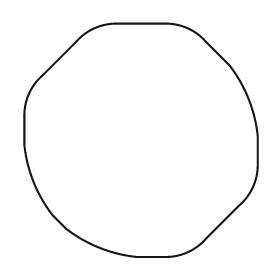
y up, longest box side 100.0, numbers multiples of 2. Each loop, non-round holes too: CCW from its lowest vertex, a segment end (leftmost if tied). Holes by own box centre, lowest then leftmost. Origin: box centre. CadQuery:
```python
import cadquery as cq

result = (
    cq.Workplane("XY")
    .moveTo(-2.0, -50.0)
    .lineTo(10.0, -50.0)
    .threePointArc((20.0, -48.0), (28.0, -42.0))
    .lineTo(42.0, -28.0)
    .threePointArc((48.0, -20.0), (50.0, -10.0))
    .lineTo(50.0, 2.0)
    .threePointArc((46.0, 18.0), (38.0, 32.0))
    .lineTo(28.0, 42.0)
    .threePointArc((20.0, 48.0), (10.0, 50.0))
    .lineTo(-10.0, 50.0)
    .threePointArc((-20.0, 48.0), (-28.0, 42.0))
    .lineTo(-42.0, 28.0)
    .threePointArc((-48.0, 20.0), (-50.0, 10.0))
    .lineTo(-50.0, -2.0)
    .threePointArc((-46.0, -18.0), (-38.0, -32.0))
    .lineTo(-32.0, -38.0)
    .threePointArc((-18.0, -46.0), (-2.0, -50.0))
    .close()
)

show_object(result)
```